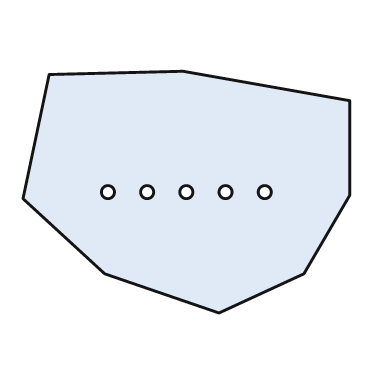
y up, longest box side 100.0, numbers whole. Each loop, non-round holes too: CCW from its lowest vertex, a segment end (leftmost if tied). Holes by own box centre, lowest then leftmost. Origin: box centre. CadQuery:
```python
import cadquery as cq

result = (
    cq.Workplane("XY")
    .moveTo(10.0, -37.0)
    .lineTo(36.0, -25.0)
    .lineTo(50.0, -1.0)
    .lineTo(50.0, 28.0)
    .lineTo(-1.0, 37.0)
    .lineTo(-42.0, 36.0)
    .lineTo(-50.0, -2.0)
    .lineTo(-25.0, -25.0)
    .close()
    .moveTo(-24.0, 0.0)
    .circle(2.0)
    .moveTo(-12.0, 0.0)
    .circle(2.0)
    .moveTo(0.0, 0.0)
    .circle(2.0)
    .moveTo(12.0, 0.0)
    .circle(2.0)
    .moveTo(24.0, 0.0)
    .circle(2.0)
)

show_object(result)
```